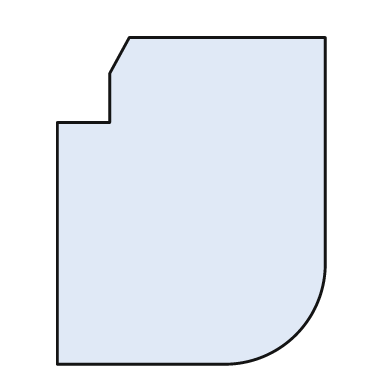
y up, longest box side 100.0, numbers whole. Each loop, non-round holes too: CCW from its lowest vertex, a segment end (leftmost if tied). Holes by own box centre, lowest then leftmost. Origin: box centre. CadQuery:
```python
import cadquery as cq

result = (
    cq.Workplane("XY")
    .moveTo(-41.0, -50.0)
    .lineTo(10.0, -50.0)
    .threePointArc((32.0, -41.0), (41.0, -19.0))
    .lineTo(41.0, 50.0)
    .lineTo(-19.0, 50.0)
    .lineTo(-25.0, 39.0)
    .lineTo(-25.0, 24.0)
    .lineTo(-41.0, 24.0)
    .close()
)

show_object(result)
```